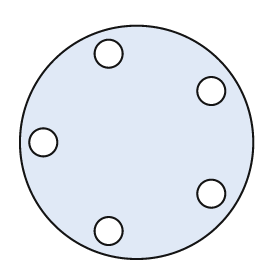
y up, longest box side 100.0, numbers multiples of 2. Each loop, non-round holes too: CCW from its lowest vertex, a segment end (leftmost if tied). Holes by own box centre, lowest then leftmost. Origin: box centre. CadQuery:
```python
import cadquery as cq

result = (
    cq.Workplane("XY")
    .moveTo(0.0, 0.0)
    .circle(50.0)
    .moveTo(-12.0, -38.0)
    .circle(6.0)
    .moveTo(32.0, -22.0)
    .circle(6.0)
    .moveTo(-40.0, 0.0)
    .circle(6.0)
    .moveTo(32.0, 22.0)
    .circle(6.0)
    .moveTo(-12.0, 38.0)
    .circle(6.0)
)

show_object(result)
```